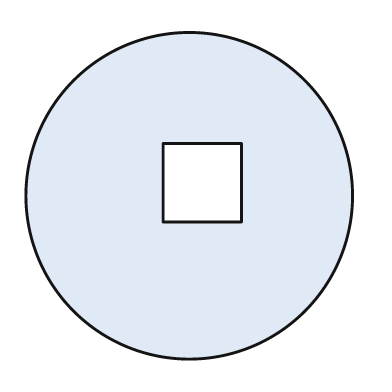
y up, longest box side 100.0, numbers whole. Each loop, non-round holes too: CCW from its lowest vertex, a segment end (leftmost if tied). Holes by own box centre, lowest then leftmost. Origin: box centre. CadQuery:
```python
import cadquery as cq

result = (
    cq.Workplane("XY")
    .moveTo(0.0, 0.0)
    .circle(50.0)
    .moveTo(-8.0, -8.0)
    .lineTo(16.0, -8.0)
    .lineTo(16.0, 16.0)
    .lineTo(-8.0, 16.0)
    .close()
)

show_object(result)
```